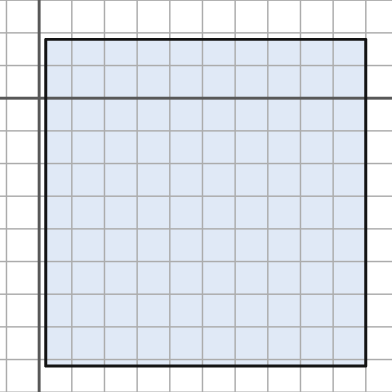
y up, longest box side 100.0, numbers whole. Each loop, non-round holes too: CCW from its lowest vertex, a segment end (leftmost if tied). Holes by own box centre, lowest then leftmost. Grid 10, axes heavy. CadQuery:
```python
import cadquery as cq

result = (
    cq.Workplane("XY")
    .moveTo(2.0, -82.0)
    .lineTo(100.0, -82.0)
    .lineTo(100.0, 18.0)
    .lineTo(2.0, 18.0)
    .close()
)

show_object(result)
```